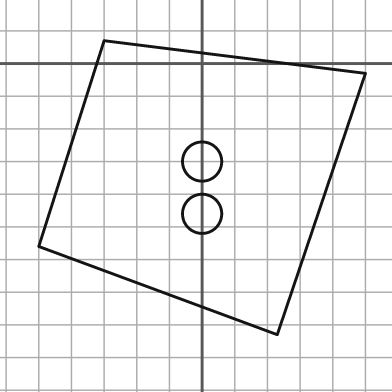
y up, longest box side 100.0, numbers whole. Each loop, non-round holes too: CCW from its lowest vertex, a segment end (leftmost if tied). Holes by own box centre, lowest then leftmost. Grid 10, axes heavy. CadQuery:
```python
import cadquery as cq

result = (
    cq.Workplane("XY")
    .moveTo(23.0, -83.0)
    .lineTo(50.0, -3.0)
    .lineTo(-30.0, 7.0)
    .lineTo(-50.0, -56.0)
    .close()
    .moveTo(0.0, -46.0)
    .circle(6.0)
    .moveTo(0.0, -30.0)
    .circle(6.0)
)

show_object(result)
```